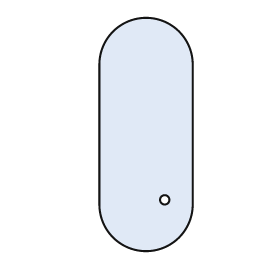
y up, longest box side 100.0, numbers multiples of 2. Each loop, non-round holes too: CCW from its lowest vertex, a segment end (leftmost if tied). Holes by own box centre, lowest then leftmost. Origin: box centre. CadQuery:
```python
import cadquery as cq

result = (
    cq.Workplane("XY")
    .moveTo(-20.0, -30.0)
    .threePointArc((0.0, -50.0), (20.0, -30.0))
    .lineTo(20.0, 30.0)
    .threePointArc((0.0, 50.0), (-20.0, 30.0))
    .close()
    .moveTo(8.0, -28.0)
    .circle(2.0)
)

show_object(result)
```